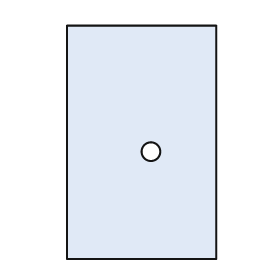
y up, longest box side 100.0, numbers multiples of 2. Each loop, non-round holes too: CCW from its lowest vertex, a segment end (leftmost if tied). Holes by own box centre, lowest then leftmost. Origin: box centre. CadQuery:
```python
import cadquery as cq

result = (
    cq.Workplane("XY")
    .moveTo(-32.0, -50.0)
    .lineTo(32.0, -50.0)
    .lineTo(32.0, 50.0)
    .lineTo(-32.0, 50.0)
    .close()
    .moveTo(4.0, -4.0)
    .circle(4.0)
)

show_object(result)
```